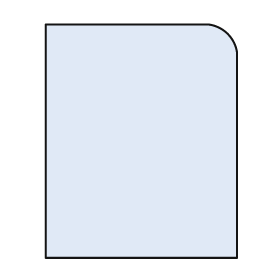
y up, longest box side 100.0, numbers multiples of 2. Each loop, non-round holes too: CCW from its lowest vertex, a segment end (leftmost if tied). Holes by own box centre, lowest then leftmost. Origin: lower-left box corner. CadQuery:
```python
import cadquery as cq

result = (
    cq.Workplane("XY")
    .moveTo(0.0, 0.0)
    .lineTo(82.0, 0.0)
    .lineTo(82.0, 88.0)
    .threePointArc((78.0, 96.0), (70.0, 100.0))
    .lineTo(0.0, 100.0)
    .close()
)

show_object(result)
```